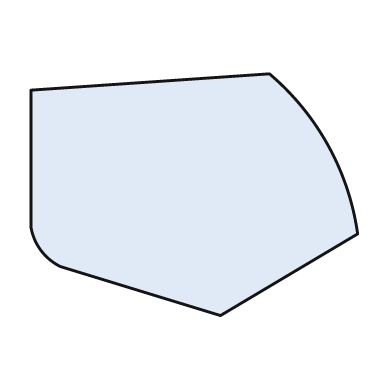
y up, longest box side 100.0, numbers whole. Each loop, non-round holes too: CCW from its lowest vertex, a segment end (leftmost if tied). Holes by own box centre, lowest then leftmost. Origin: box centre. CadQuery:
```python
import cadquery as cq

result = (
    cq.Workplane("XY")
    .moveTo(8.0, -37.0)
    .lineTo(50.0, -12.0)
    .threePointArc((41.0, 15.0), (23.0, 37.0))
    .lineTo(-50.0, 32.0)
    .lineTo(-50.0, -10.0)
    .threePointArc((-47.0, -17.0), (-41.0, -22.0))
    .close()
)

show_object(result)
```